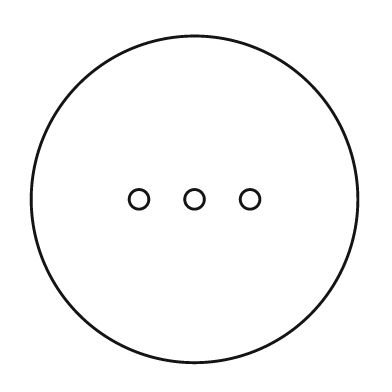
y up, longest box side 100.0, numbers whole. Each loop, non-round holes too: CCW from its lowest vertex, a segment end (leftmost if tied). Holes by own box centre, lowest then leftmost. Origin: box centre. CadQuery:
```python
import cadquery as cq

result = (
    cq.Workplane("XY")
    .moveTo(0.0, 0.0)
    .circle(50.0)
    .moveTo(-17.0, 0.0)
    .circle(3.0)
    .moveTo(0.0, 0.0)
    .circle(3.0)
    .moveTo(17.0, 0.0)
    .circle(3.0)
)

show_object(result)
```